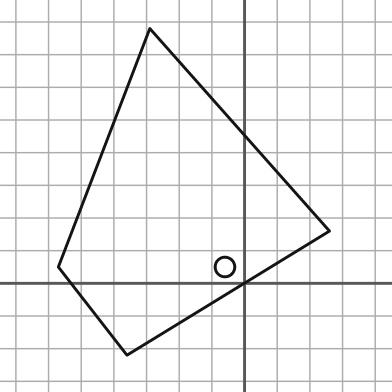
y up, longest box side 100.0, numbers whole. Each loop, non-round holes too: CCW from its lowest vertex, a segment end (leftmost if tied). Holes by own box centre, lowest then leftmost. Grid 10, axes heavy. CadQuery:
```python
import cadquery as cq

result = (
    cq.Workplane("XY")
    .moveTo(-36.0, -22.0)
    .lineTo(26.0, 16.0)
    .lineTo(-29.0, 78.0)
    .lineTo(-57.0, 5.0)
    .close()
    .moveTo(-6.0, 5.0)
    .circle(3.0)
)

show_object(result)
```